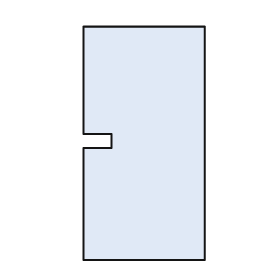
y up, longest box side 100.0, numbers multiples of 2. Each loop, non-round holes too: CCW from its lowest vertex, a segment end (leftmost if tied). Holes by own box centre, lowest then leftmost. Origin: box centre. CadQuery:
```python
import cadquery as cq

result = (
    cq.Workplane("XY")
    .moveTo(-26.0, -50.0)
    .lineTo(26.0, -50.0)
    .lineTo(26.0, 50.0)
    .lineTo(-26.0, 50.0)
    .lineTo(-26.0, 4.0)
    .lineTo(-14.0, 4.0)
    .lineTo(-14.0, -2.0)
    .lineTo(-26.0, -2.0)
    .close()
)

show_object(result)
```